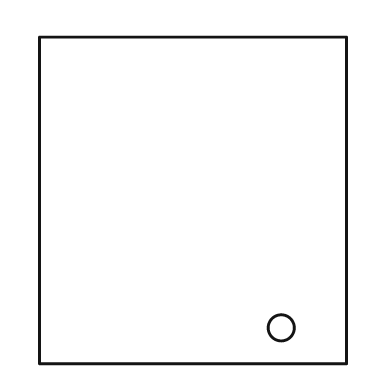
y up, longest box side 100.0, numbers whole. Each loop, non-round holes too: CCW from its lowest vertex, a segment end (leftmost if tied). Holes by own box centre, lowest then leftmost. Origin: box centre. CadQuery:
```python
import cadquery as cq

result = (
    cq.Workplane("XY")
    .moveTo(-47.0, -50.0)
    .lineTo(47.0, -50.0)
    .lineTo(47.0, 50.0)
    .lineTo(-47.0, 50.0)
    .close()
    .moveTo(27.0, -39.0)
    .circle(4.0)
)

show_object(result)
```